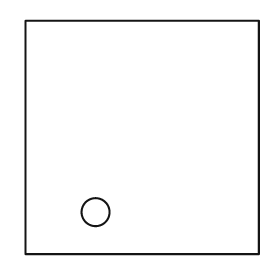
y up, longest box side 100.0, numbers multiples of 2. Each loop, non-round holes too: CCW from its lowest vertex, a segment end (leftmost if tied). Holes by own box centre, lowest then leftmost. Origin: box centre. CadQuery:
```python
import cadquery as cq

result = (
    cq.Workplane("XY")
    .moveTo(-50.0, -50.0)
    .lineTo(50.0, -50.0)
    .lineTo(50.0, 50.0)
    .lineTo(-50.0, 50.0)
    .close()
    .moveTo(-20.0, -32.0)
    .circle(6.0)
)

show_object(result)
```